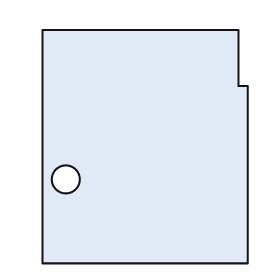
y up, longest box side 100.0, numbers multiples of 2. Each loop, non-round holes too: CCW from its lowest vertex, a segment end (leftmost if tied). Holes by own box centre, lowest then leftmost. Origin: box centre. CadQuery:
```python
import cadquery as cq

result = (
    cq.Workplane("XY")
    .moveTo(-44.0, -50.0)
    .lineTo(44.0, -50.0)
    .lineTo(44.0, 26.0)
    .lineTo(40.0, 26.0)
    .lineTo(40.0, 50.0)
    .lineTo(-44.0, 50.0)
    .close()
    .moveTo(-34.0, -14.0)
    .circle(6.0)
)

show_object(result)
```